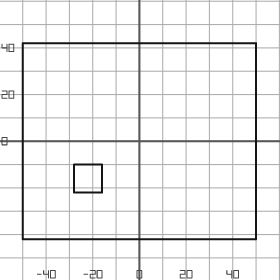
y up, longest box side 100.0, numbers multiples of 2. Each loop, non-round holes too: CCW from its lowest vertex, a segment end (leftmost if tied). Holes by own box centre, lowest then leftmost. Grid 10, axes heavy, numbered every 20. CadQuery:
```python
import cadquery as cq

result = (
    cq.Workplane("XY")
    .moveTo(-50.0, -42.0)
    .lineTo(50.0, -42.0)
    .lineTo(50.0, 42.0)
    .lineTo(-50.0, 42.0)
    .close()
    .moveTo(-28.0, -22.0)
    .lineTo(-16.0, -22.0)
    .lineTo(-16.0, -10.0)
    .lineTo(-28.0, -10.0)
    .close()
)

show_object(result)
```